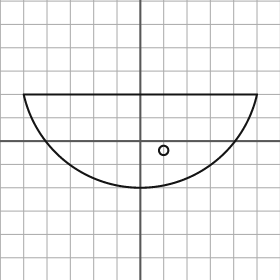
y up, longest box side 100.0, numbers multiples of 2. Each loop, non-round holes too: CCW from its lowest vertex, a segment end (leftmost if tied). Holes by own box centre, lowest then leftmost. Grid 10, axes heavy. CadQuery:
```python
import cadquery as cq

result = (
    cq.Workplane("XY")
    .moveTo(-50.0, 20.0)
    .threePointArc((0.0, -20.0), (50.0, 20.0))
    .close()
    .moveTo(10.0, -4.0)
    .circle(2.0)
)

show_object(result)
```